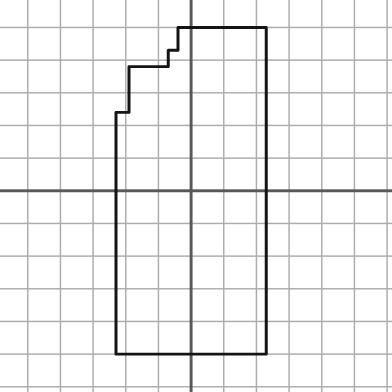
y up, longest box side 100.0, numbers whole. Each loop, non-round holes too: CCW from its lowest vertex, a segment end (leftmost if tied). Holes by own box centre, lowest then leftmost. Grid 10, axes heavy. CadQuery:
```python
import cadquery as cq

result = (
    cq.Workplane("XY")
    .moveTo(-23.0, -50.0)
    .lineTo(23.0, -50.0)
    .lineTo(23.0, 50.0)
    .lineTo(-4.0, 50.0)
    .lineTo(-4.0, 43.0)
    .lineTo(-7.0, 43.0)
    .lineTo(-7.0, 38.0)
    .lineTo(-19.0, 38.0)
    .lineTo(-19.0, 24.0)
    .lineTo(-23.0, 24.0)
    .close()
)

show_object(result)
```